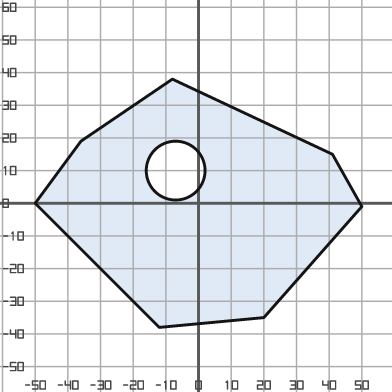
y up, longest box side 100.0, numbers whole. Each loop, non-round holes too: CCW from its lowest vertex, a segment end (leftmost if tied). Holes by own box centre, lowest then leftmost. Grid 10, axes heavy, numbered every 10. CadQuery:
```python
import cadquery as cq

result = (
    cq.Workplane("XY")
    .moveTo(-12.0, -38.0)
    .lineTo(20.0, -35.0)
    .lineTo(50.0, -1.0)
    .lineTo(41.0, 15.0)
    .lineTo(-8.0, 38.0)
    .lineTo(-36.0, 19.0)
    .lineTo(-50.0, 0.0)
    .close()
    .moveTo(-7.0, 10.0)
    .circle(9.0)
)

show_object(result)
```